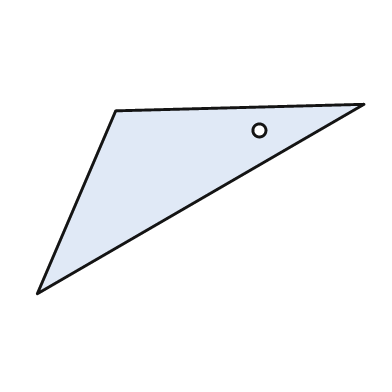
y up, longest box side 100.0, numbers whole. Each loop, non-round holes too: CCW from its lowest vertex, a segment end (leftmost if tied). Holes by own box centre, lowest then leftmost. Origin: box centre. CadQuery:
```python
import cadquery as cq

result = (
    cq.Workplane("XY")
    .moveTo(-50.0, -29.0)
    .lineTo(50.0, 29.0)
    .lineTo(-26.0, 27.0)
    .close()
    .moveTo(18.0, 21.0)
    .circle(2.0)
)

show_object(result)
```